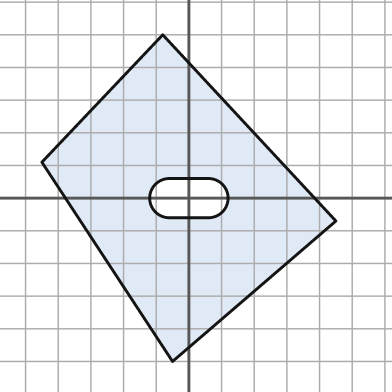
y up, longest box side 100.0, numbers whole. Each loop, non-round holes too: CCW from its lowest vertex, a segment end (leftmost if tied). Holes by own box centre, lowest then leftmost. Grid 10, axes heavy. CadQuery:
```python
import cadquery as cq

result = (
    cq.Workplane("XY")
    .moveTo(-5.0, -50.0)
    .lineTo(45.0, -7.0)
    .lineTo(-8.0, 50.0)
    .lineTo(-45.0, 11.0)
    .close()
    .moveTo(-6.0, -6.0)
    .lineTo(6.0, -6.0)
    .threePointArc((12.0, 0.0), (6.0, 6.0))
    .lineTo(-6.0, 6.0)
    .threePointArc((-12.0, 0.0), (-6.0, -6.0))
    .close()
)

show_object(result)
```